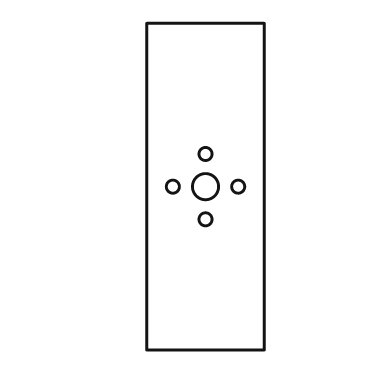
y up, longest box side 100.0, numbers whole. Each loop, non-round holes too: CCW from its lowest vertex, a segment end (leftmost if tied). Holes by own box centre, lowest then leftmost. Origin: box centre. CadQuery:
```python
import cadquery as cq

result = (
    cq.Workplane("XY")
    .moveTo(-18.0, -50.0)
    .lineTo(18.0, -50.0)
    .lineTo(18.0, 50.0)
    .lineTo(-18.0, 50.0)
    .close()
    .moveTo(0.0, -10.0)
    .circle(2.0)
    .moveTo(-10.0, 0.0)
    .circle(2.0)
    .moveTo(0.0, 0.0)
    .circle(4.0)
    .moveTo(10.0, 0.0)
    .circle(2.0)
    .moveTo(0.0, 10.0)
    .circle(2.0)
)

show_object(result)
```